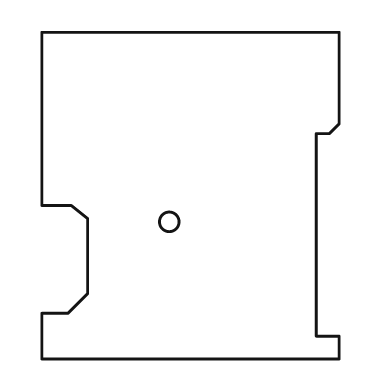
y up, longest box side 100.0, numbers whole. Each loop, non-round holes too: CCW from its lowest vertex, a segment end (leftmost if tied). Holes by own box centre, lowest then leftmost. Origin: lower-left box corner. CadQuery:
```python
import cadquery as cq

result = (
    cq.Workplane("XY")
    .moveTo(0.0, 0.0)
    .lineTo(91.0, 0.0)
    .lineTo(91.0, 7.0)
    .lineTo(84.0, 7.0)
    .lineTo(84.0, 69.0)
    .lineTo(88.0, 69.0)
    .lineTo(91.0, 72.0)
    .lineTo(91.0, 100.0)
    .lineTo(0.0, 100.0)
    .lineTo(0.0, 47.0)
    .lineTo(9.0, 47.0)
    .lineTo(14.0, 43.0)
    .lineTo(14.0, 20.0)
    .lineTo(8.0, 14.0)
    .lineTo(0.0, 14.0)
    .close()
    .moveTo(39.0, 42.0)
    .circle(3.0)
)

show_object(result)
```